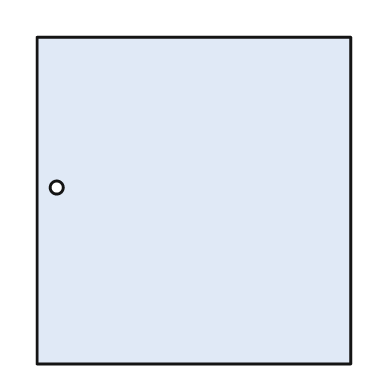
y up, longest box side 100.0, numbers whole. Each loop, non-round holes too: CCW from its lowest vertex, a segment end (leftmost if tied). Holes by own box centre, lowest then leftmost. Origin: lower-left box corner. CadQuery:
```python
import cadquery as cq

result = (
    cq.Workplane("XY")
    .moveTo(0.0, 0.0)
    .lineTo(96.0, 0.0)
    .lineTo(96.0, 100.0)
    .lineTo(0.0, 100.0)
    .close()
    .moveTo(6.0, 54.0)
    .circle(2.0)
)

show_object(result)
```